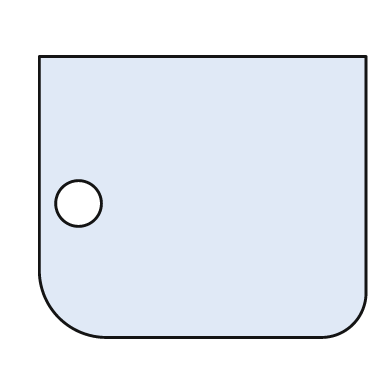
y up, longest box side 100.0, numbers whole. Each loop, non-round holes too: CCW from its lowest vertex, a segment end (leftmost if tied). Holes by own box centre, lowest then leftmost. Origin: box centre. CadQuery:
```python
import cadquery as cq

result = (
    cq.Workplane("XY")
    .moveTo(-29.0, -43.0)
    .lineTo(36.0, -43.0)
    .threePointArc((46.0, -39.0), (50.0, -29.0))
    .lineTo(50.0, 43.0)
    .lineTo(-50.0, 43.0)
    .lineTo(-50.0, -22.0)
    .threePointArc((-44.0, -37.0), (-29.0, -43.0))
    .close()
    .moveTo(-38.0, -2.0)
    .circle(7.0)
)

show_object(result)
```